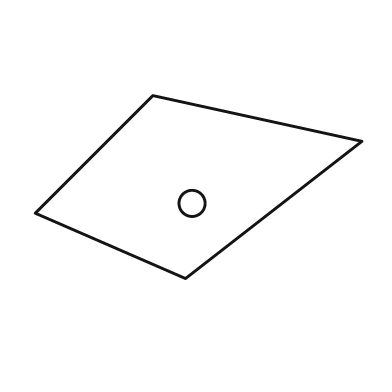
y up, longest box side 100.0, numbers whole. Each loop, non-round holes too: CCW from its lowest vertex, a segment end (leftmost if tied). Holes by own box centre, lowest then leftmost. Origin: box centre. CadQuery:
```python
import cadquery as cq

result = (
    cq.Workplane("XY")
    .moveTo(-4.0, -28.0)
    .lineTo(50.0, 14.0)
    .lineTo(-14.0, 28.0)
    .lineTo(-50.0, -8.0)
    .close()
    .moveTo(-2.0, -5.0)
    .circle(4.0)
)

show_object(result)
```